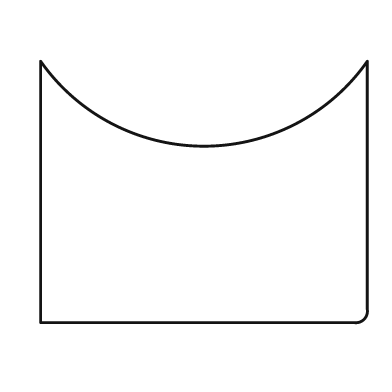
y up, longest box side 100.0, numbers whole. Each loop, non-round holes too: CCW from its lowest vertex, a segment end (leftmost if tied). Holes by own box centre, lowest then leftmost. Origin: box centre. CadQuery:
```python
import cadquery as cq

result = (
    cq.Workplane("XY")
    .moveTo(-50.0, -40.0)
    .lineTo(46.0, -40.0)
    .threePointArc((49.0, -39.0), (50.0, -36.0))
    .lineTo(50.0, 40.0)
    .threePointArc((0.0, 14.0), (-50.0, 40.0))
    .close()
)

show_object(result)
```